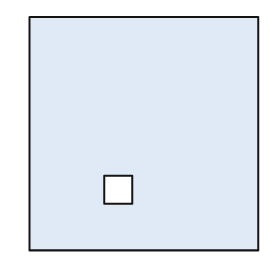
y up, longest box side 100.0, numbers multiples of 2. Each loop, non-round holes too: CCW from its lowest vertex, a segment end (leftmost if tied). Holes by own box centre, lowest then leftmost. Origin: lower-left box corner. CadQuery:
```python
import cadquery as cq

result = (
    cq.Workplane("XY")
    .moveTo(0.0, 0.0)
    .lineTo(98.0, 0.0)
    .lineTo(98.0, 100.0)
    .lineTo(0.0, 100.0)
    .close()
    .moveTo(32.0, 20.0)
    .lineTo(44.0, 20.0)
    .lineTo(44.0, 32.0)
    .lineTo(32.0, 32.0)
    .close()
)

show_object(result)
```